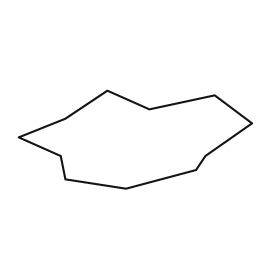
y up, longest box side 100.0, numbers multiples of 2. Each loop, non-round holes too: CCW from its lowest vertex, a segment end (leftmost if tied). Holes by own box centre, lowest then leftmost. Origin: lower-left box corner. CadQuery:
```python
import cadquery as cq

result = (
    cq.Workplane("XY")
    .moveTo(46.0, 0.0)
    .lineTo(76.0, 8.0)
    .lineTo(80.0, 14.0)
    .lineTo(100.0, 28.0)
    .lineTo(84.0, 40.0)
    .lineTo(56.0, 34.0)
    .lineTo(38.0, 42.0)
    .lineTo(20.0, 30.0)
    .lineTo(0.0, 22.0)
    .lineTo(18.0, 14.0)
    .lineTo(20.0, 4.0)
    .close()
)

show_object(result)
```